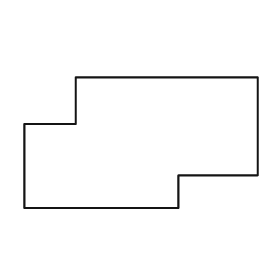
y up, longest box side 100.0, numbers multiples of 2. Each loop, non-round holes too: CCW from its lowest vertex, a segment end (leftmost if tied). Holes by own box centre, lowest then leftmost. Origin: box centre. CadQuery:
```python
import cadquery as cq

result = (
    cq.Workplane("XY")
    .moveTo(-50.0, -28.0)
    .lineTo(16.0, -28.0)
    .lineTo(16.0, -14.0)
    .lineTo(50.0, -14.0)
    .lineTo(50.0, 28.0)
    .lineTo(-28.0, 28.0)
    .lineTo(-28.0, 8.0)
    .lineTo(-50.0, 8.0)
    .close()
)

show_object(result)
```